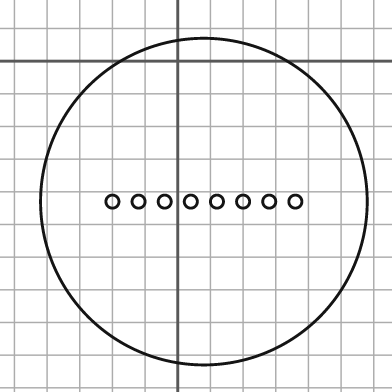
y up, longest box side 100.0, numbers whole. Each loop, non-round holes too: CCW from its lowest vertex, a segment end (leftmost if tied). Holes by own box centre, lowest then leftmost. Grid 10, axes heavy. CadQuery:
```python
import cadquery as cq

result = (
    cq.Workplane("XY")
    .moveTo(8.0, -43.0)
    .circle(50.0)
    .moveTo(-20.0, -43.0)
    .circle(2.0)
    .moveTo(-12.0, -43.0)
    .circle(2.0)
    .moveTo(-4.0, -43.0)
    .circle(2.0)
    .moveTo(4.0, -43.0)
    .circle(2.0)
    .moveTo(12.0, -43.0)
    .circle(2.0)
    .moveTo(20.0, -43.0)
    .circle(2.0)
    .moveTo(28.0, -43.0)
    .circle(2.0)
    .moveTo(36.0, -43.0)
    .circle(2.0)
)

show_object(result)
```